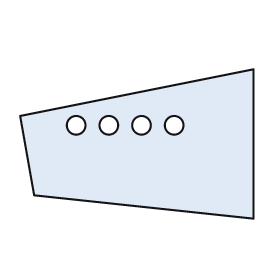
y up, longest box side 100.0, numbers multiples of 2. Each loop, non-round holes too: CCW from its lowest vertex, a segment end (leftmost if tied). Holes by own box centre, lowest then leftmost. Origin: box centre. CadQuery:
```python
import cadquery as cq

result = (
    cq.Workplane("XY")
    .moveTo(50.0, -32.0)
    .lineTo(50.0, 32.0)
    .lineTo(-50.0, 12.0)
    .lineTo(-44.0, -22.0)
    .close()
    .moveTo(-26.0, 8.0)
    .circle(4.0)
    .moveTo(-12.0, 8.0)
    .circle(4.0)
    .moveTo(2.0, 8.0)
    .circle(4.0)
    .moveTo(16.0, 8.0)
    .circle(4.0)
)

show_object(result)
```